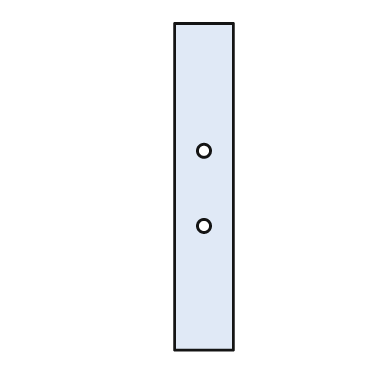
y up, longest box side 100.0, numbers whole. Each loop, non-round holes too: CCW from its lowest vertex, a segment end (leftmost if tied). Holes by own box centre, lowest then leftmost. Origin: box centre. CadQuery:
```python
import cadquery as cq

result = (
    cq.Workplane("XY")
    .moveTo(-9.0, -50.0)
    .lineTo(9.0, -50.0)
    .lineTo(9.0, 50.0)
    .lineTo(-9.0, 50.0)
    .close()
    .moveTo(0.0, -12.0)
    .circle(2.0)
    .moveTo(0.0, 11.0)
    .circle(2.0)
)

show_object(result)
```